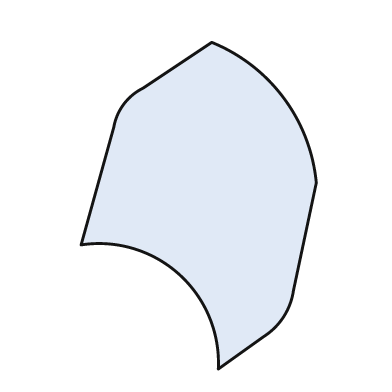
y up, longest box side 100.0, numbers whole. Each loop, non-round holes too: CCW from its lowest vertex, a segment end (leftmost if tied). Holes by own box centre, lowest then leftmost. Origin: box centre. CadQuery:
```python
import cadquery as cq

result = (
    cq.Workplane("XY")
    .moveTo(6.0, -50.0)
    .lineTo(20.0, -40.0)
    .threePointArc((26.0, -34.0), (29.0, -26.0))
    .lineTo(36.0, 7.0)
    .threePointArc((26.0, 33.0), (4.0, 50.0))
    .lineTo(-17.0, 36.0)
    .threePointArc((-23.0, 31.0), (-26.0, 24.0))
    .lineTo(-36.0, -12.0)
    .threePointArc((-6.0, -21.0), (6.0, -50.0))
    .close()
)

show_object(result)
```